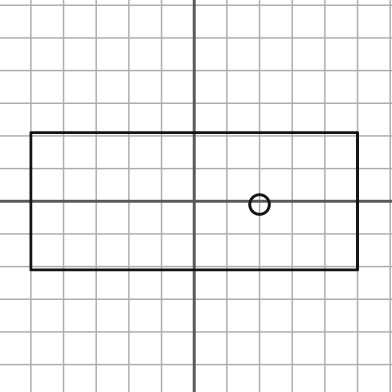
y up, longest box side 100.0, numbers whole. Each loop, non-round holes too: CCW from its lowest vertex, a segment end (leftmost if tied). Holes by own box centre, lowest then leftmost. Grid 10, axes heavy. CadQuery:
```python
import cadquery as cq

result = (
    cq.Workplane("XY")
    .moveTo(-50.0, -21.0)
    .lineTo(50.0, -21.0)
    .lineTo(50.0, 21.0)
    .lineTo(-50.0, 21.0)
    .close()
    .moveTo(20.0, -1.0)
    .circle(3.0)
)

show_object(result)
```